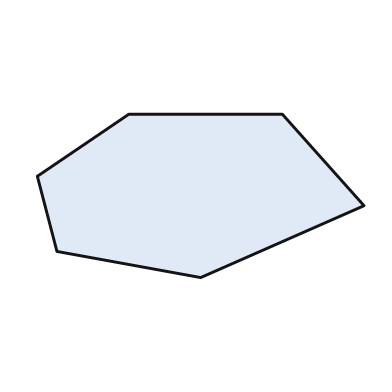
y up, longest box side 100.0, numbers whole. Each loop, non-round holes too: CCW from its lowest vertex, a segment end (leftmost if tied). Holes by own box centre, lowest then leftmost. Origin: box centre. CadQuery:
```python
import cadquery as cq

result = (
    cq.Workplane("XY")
    .moveTo(0.0, -25.0)
    .lineTo(50.0, -3.0)
    .lineTo(25.0, 25.0)
    .lineTo(-22.0, 25.0)
    .lineTo(-50.0, 6.0)
    .lineTo(-44.0, -17.0)
    .close()
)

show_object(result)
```